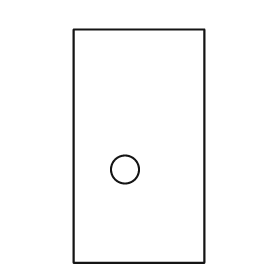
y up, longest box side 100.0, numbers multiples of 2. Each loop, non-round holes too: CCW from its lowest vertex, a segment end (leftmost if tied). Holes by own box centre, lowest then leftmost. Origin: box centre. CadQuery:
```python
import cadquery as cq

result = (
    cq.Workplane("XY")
    .moveTo(-28.0, -50.0)
    .lineTo(28.0, -50.0)
    .lineTo(28.0, 50.0)
    .lineTo(-28.0, 50.0)
    .close()
    .moveTo(-6.0, -10.0)
    .circle(6.0)
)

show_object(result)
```